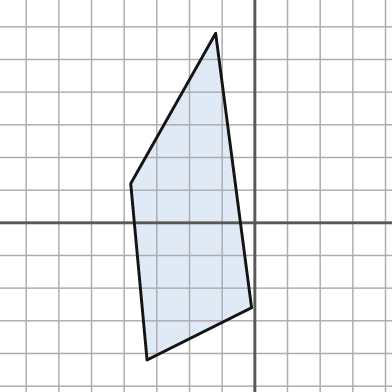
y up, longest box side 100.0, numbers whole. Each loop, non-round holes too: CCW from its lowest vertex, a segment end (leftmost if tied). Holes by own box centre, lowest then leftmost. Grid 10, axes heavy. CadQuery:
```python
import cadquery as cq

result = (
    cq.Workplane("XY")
    .moveTo(-33.0, -42.0)
    .lineTo(-1.0, -26.0)
    .lineTo(-12.0, 58.0)
    .lineTo(-38.0, 12.0)
    .close()
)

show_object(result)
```